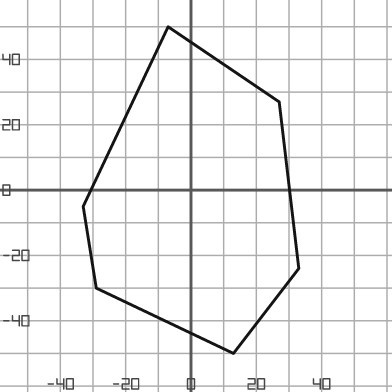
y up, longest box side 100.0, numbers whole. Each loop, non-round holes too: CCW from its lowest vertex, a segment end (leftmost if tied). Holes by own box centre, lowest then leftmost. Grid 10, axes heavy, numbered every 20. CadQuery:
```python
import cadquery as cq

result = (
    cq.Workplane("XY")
    .moveTo(13.0, -50.0)
    .lineTo(33.0, -24.0)
    .lineTo(27.0, 27.0)
    .lineTo(-7.0, 50.0)
    .lineTo(-33.0, -5.0)
    .lineTo(-29.0, -30.0)
    .close()
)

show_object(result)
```